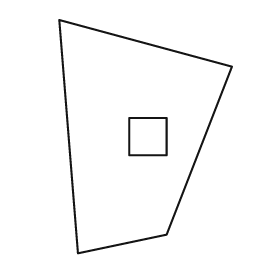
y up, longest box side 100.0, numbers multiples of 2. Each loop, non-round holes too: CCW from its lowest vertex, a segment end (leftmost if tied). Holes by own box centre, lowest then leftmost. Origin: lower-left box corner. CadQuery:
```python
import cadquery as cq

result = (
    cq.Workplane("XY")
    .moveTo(8.0, 0.0)
    .lineTo(46.0, 8.0)
    .lineTo(74.0, 80.0)
    .lineTo(0.0, 100.0)
    .close()
    .moveTo(30.0, 42.0)
    .lineTo(46.0, 42.0)
    .lineTo(46.0, 58.0)
    .lineTo(30.0, 58.0)
    .close()
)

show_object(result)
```